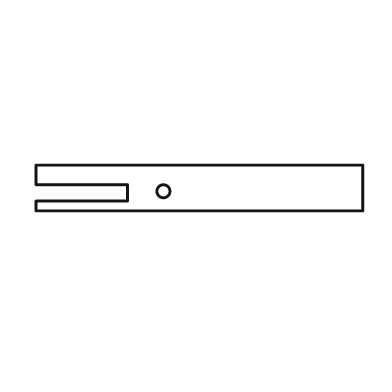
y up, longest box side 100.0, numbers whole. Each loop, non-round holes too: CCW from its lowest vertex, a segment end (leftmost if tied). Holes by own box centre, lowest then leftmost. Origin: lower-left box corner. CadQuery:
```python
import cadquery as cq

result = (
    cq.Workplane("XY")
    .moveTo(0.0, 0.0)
    .lineTo(100.0, 0.0)
    .lineTo(100.0, 14.0)
    .lineTo(0.0, 14.0)
    .lineTo(0.0, 8.0)
    .lineTo(28.0, 8.0)
    .lineTo(28.0, 3.0)
    .lineTo(0.0, 3.0)
    .close()
    .moveTo(39.0, 6.0)
    .circle(2.0)
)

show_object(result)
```